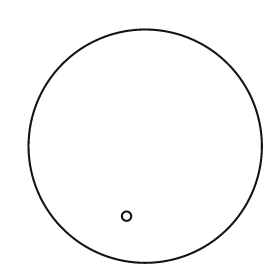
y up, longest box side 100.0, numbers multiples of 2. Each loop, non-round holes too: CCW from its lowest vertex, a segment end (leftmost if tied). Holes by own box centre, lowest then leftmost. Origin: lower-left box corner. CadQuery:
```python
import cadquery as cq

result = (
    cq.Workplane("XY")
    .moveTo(50.0, 50.0)
    .circle(50.0)
    .moveTo(42.0, 20.0)
    .circle(2.0)
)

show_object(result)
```